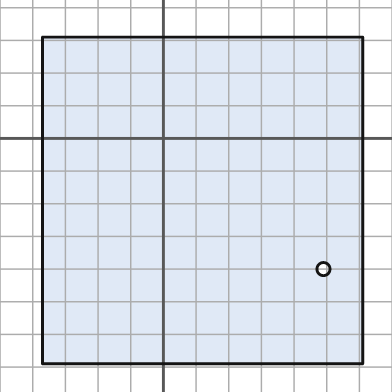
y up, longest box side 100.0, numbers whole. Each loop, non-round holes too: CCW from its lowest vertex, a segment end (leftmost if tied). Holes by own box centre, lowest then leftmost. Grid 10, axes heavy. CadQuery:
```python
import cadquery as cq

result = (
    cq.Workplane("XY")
    .moveTo(-37.0, -69.0)
    .lineTo(61.0, -69.0)
    .lineTo(61.0, 31.0)
    .lineTo(-37.0, 31.0)
    .close()
    .moveTo(49.0, -40.0)
    .circle(2.0)
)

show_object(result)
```